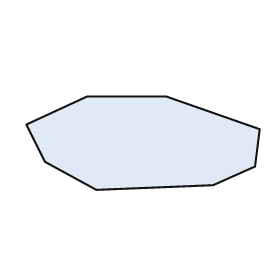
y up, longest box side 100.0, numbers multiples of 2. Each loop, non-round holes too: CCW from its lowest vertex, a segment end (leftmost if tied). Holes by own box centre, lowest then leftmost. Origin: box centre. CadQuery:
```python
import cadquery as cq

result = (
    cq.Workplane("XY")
    .moveTo(-20.0, -20.0)
    .lineTo(30.0, -18.0)
    .lineTo(48.0, -10.0)
    .lineTo(50.0, 6.0)
    .lineTo(10.0, 20.0)
    .lineTo(-24.0, 20.0)
    .lineTo(-50.0, 8.0)
    .lineTo(-42.0, -8.0)
    .close()
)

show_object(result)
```